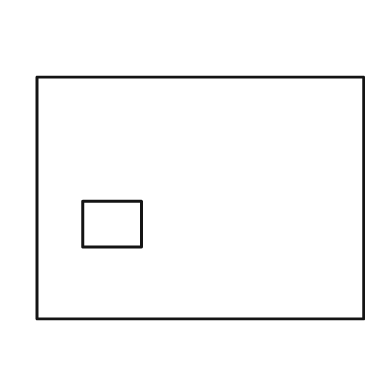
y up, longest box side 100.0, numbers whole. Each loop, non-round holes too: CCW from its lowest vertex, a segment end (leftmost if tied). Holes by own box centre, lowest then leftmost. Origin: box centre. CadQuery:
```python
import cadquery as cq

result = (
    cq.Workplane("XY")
    .moveTo(-50.0, -37.0)
    .lineTo(50.0, -37.0)
    .lineTo(50.0, 37.0)
    .lineTo(-50.0, 37.0)
    .close()
    .moveTo(-36.0, -15.0)
    .lineTo(-18.0, -15.0)
    .lineTo(-18.0, -1.0)
    .lineTo(-36.0, -1.0)
    .close()
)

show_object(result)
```